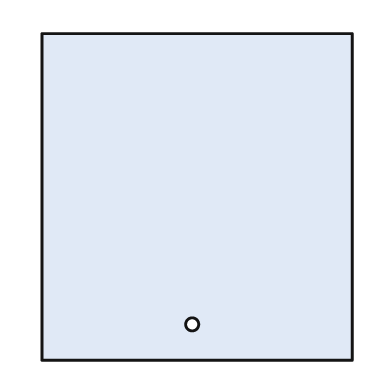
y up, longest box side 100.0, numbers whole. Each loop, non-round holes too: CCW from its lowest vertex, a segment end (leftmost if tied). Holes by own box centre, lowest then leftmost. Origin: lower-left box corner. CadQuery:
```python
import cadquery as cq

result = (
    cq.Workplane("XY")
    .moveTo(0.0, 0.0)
    .lineTo(95.0, 0.0)
    .lineTo(95.0, 100.0)
    .lineTo(0.0, 100.0)
    .close()
    .moveTo(46.0, 11.0)
    .circle(2.0)
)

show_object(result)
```